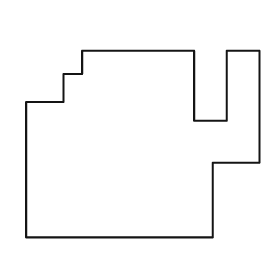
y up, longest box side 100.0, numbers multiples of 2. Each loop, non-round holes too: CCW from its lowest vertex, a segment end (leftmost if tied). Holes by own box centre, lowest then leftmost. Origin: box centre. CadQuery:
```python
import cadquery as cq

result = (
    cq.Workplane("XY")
    .moveTo(-50.0, -40.0)
    .lineTo(30.0, -40.0)
    .lineTo(30.0, -8.0)
    .lineTo(50.0, -8.0)
    .lineTo(50.0, 40.0)
    .lineTo(36.0, 40.0)
    .lineTo(36.0, 10.0)
    .lineTo(22.0, 10.0)
    .lineTo(22.0, 40.0)
    .lineTo(-26.0, 40.0)
    .lineTo(-26.0, 30.0)
    .lineTo(-34.0, 30.0)
    .lineTo(-34.0, 18.0)
    .lineTo(-50.0, 18.0)
    .close()
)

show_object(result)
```